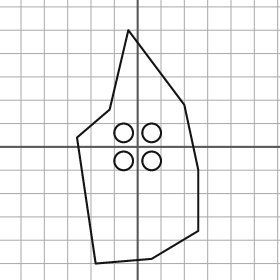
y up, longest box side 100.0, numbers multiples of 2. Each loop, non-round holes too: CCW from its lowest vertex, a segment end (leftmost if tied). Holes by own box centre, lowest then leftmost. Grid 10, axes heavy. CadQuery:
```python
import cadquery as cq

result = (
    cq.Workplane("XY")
    .moveTo(-18.0, -50.0)
    .lineTo(6.0, -48.0)
    .lineTo(26.0, -36.0)
    .lineTo(26.0, -10.0)
    .lineTo(20.0, 18.0)
    .lineTo(-4.0, 50.0)
    .lineTo(-12.0, 16.0)
    .lineTo(-26.0, 4.0)
    .close()
    .moveTo(-6.0, -6.0)
    .circle(4.0)
    .moveTo(6.0, -6.0)
    .circle(4.0)
    .moveTo(-6.0, 6.0)
    .circle(4.0)
    .moveTo(6.0, 6.0)
    .circle(4.0)
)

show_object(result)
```